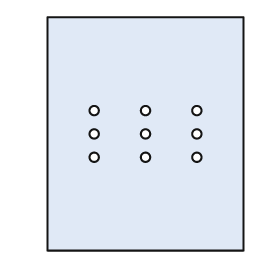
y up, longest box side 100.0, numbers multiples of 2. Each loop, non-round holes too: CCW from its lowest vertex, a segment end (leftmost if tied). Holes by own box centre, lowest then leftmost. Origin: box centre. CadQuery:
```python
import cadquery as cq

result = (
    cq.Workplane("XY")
    .moveTo(-42.0, -50.0)
    .lineTo(42.0, -50.0)
    .lineTo(42.0, 50.0)
    .lineTo(-42.0, 50.0)
    .close()
    .moveTo(-22.0, -10.0)
    .circle(2.0)
    .moveTo(0.0, -10.0)
    .circle(2.0)
    .moveTo(22.0, -10.0)
    .circle(2.0)
    .moveTo(-22.0, 0.0)
    .circle(2.0)
    .moveTo(0.0, 0.0)
    .circle(2.0)
    .moveTo(22.0, 0.0)
    .circle(2.0)
    .moveTo(-22.0, 10.0)
    .circle(2.0)
    .moveTo(0.0, 10.0)
    .circle(2.0)
    .moveTo(22.0, 10.0)
    .circle(2.0)
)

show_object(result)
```